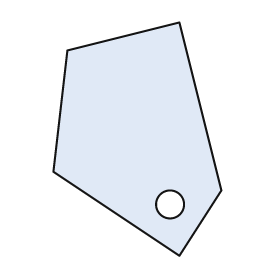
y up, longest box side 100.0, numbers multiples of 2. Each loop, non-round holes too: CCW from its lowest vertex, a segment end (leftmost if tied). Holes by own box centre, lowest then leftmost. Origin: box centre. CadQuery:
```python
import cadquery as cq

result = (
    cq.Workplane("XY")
    .moveTo(18.0, -50.0)
    .lineTo(36.0, -22.0)
    .lineTo(18.0, 50.0)
    .lineTo(-30.0, 38.0)
    .lineTo(-36.0, -14.0)
    .close()
    .moveTo(14.0, -28.0)
    .circle(6.0)
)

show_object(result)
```